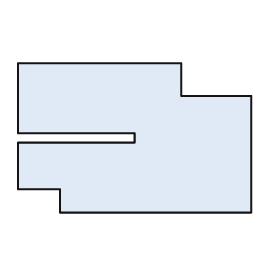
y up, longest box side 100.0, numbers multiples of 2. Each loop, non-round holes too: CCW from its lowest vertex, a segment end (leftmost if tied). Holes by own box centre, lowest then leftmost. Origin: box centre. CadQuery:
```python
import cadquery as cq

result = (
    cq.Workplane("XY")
    .moveTo(-32.0, -32.0)
    .lineTo(50.0, -32.0)
    .lineTo(50.0, 18.0)
    .lineTo(20.0, 18.0)
    .lineTo(20.0, 32.0)
    .lineTo(-50.0, 32.0)
    .lineTo(-50.0, 2.0)
    .lineTo(0.0, 2.0)
    .lineTo(0.0, -2.0)
    .lineTo(-50.0, -2.0)
    .lineTo(-50.0, -22.0)
    .lineTo(-32.0, -22.0)
    .close()
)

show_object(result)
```